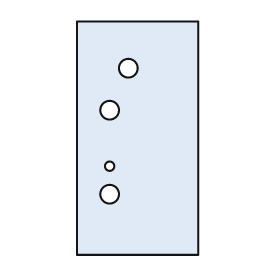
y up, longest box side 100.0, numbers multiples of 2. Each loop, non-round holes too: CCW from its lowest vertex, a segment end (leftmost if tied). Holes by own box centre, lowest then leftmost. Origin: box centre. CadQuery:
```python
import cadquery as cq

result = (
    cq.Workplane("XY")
    .moveTo(-26.0, -50.0)
    .lineTo(26.0, -50.0)
    .lineTo(26.0, 50.0)
    .lineTo(-26.0, 50.0)
    .close()
    .moveTo(-12.0, -24.0)
    .circle(4.0)
    .moveTo(-12.0, -12.0)
    .circle(2.0)
    .moveTo(-12.0, 12.0)
    .circle(4.0)
    .moveTo(-4.0, 30.0)
    .circle(4.0)
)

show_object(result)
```